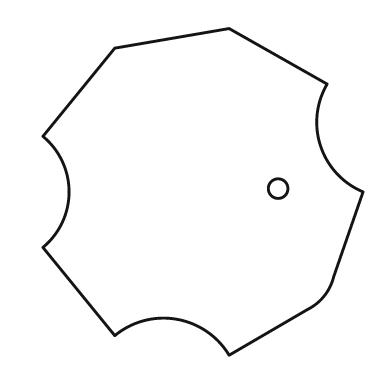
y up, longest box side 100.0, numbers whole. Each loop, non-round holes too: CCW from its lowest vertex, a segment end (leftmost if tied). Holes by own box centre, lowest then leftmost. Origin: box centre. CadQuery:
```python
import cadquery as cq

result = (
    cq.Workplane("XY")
    .moveTo(8.0, -50.0)
    .lineTo(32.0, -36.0)
    .threePointArc((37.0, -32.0), (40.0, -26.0))
    .lineTo(49.0, 0.0)
    .threePointArc((36.0, 14.0), (38.0, 33.0))
    .lineTo(8.0, 50.0)
    .lineTo(-27.0, 44.0)
    .lineTo(-49.0, 17.0)
    .threePointArc((-41.0, 0.0), (-49.0, -17.0))
    .lineTo(-27.0, -44.0)
    .threePointArc((-8.0, -39.0), (8.0, -50.0))
    .close()
    .moveTo(23.0, 1.0)
    .circle(3.0)
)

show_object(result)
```